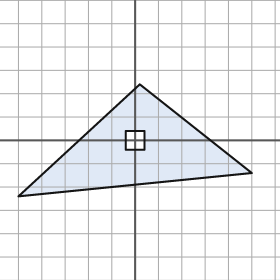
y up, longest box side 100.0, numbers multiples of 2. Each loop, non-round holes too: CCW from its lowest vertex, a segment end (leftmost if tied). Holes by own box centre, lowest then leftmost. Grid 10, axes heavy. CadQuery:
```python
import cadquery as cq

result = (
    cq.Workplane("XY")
    .moveTo(-50.0, -24.0)
    .lineTo(50.0, -14.0)
    .lineTo(2.0, 24.0)
    .close()
    .moveTo(-4.0, -4.0)
    .lineTo(4.0, -4.0)
    .lineTo(4.0, 4.0)
    .lineTo(-4.0, 4.0)
    .close()
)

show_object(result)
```